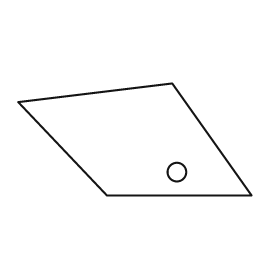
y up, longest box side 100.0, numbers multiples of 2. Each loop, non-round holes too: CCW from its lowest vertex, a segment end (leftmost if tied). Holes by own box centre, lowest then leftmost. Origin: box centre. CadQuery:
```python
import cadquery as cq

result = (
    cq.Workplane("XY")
    .moveTo(-12.0, -24.0)
    .lineTo(50.0, -24.0)
    .lineTo(16.0, 24.0)
    .lineTo(-50.0, 16.0)
    .close()
    .moveTo(18.0, -14.0)
    .circle(4.0)
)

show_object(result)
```